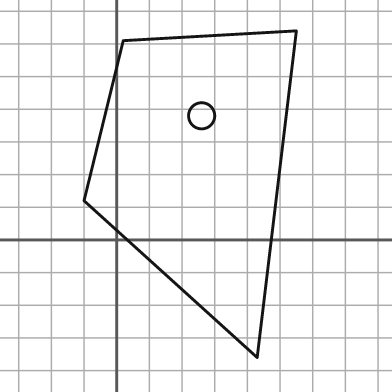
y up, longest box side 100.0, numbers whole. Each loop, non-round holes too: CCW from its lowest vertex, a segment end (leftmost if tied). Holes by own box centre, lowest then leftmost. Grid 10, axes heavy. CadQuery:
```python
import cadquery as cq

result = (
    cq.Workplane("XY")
    .moveTo(43.0, -36.0)
    .lineTo(55.0, 64.0)
    .lineTo(2.0, 61.0)
    .lineTo(-10.0, 12.0)
    .close()
    .moveTo(26.0, 38.0)
    .circle(4.0)
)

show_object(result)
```